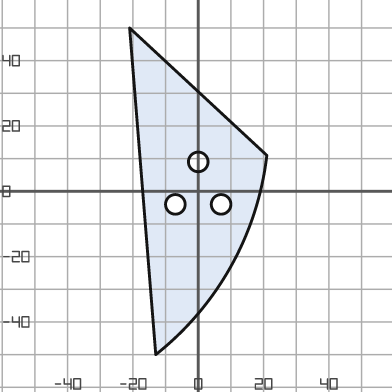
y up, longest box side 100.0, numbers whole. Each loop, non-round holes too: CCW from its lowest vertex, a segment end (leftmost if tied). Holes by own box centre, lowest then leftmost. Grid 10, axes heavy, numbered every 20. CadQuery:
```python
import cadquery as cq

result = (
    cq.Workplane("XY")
    .moveTo(-13.0, -50.0)
    .threePointArc((10.0, -23.0), (21.0, 11.0))
    .lineTo(-21.0, 50.0)
    .close()
    .moveTo(-7.0, -4.0)
    .circle(3.0)
    .moveTo(7.0, -4.0)
    .circle(3.0)
    .moveTo(0.0, 9.0)
    .circle(3.0)
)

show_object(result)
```